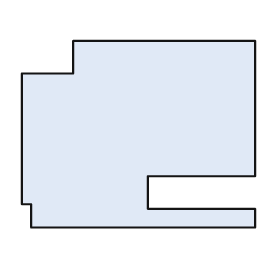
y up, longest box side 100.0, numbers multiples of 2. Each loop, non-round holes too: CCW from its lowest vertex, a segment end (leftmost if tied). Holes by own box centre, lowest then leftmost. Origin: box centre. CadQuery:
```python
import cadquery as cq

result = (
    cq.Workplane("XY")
    .moveTo(-46.0, -40.0)
    .lineTo(50.0, -40.0)
    .lineTo(50.0, -32.0)
    .lineTo(4.0, -32.0)
    .lineTo(4.0, -18.0)
    .lineTo(50.0, -18.0)
    .lineTo(50.0, 40.0)
    .lineTo(-28.0, 40.0)
    .lineTo(-28.0, 26.0)
    .lineTo(-50.0, 26.0)
    .lineTo(-50.0, -30.0)
    .lineTo(-46.0, -30.0)
    .close()
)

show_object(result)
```